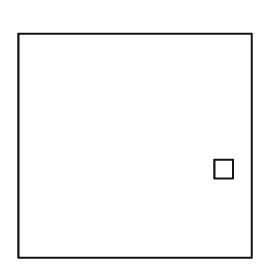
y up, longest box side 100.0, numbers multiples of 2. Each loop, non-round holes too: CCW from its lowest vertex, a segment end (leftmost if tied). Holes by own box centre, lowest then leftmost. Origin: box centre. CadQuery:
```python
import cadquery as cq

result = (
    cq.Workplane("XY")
    .moveTo(-50.0, -48.0)
    .lineTo(50.0, -48.0)
    .lineTo(50.0, 48.0)
    .lineTo(-50.0, 48.0)
    .close()
    .moveTo(34.0, -14.0)
    .lineTo(42.0, -14.0)
    .lineTo(42.0, -6.0)
    .lineTo(34.0, -6.0)
    .close()
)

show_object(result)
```